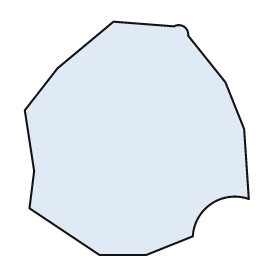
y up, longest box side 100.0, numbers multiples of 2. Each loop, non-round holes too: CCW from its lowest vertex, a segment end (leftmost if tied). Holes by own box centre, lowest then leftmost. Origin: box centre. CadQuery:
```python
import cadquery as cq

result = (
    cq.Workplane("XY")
    .moveTo(-16.0, -50.0)
    .lineTo(4.0, -50.0)
    .lineTo(24.0, -42.0)
    .threePointArc((32.0, -28.0), (48.0, -26.0))
    .lineTo(46.0, 4.0)
    .lineTo(38.0, 24.0)
    .lineTo(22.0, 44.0)
    .threePointArc((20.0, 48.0), (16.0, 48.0))
    .lineTo(-10.0, 50.0)
    .lineTo(-34.0, 30.0)
    .lineTo(-48.0, 12.0)
    .lineTo(-44.0, -14.0)
    .lineTo(-46.0, -30.0)
    .close()
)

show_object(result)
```